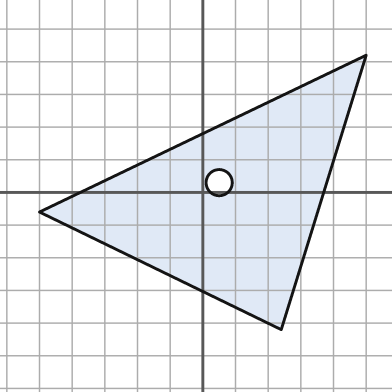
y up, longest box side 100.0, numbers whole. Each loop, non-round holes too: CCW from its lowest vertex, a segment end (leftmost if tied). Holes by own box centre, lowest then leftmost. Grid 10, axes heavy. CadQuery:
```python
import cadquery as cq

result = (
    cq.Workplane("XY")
    .moveTo(24.0, -42.0)
    .lineTo(50.0, 42.0)
    .lineTo(-50.0, -6.0)
    .close()
    .moveTo(5.0, 3.0)
    .circle(4.0)
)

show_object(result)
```